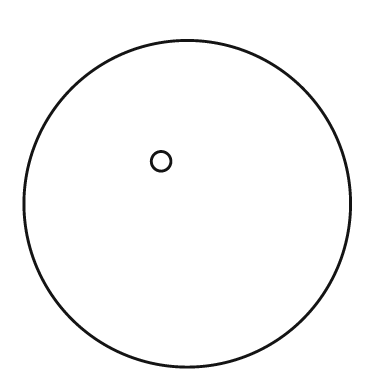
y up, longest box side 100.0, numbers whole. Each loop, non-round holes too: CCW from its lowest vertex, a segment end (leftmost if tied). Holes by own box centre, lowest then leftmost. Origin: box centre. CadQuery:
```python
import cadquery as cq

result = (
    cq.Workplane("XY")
    .moveTo(0.0, 0.0)
    .circle(50.0)
    .moveTo(-8.0, 13.0)
    .circle(3.0)
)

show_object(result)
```